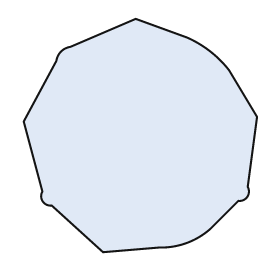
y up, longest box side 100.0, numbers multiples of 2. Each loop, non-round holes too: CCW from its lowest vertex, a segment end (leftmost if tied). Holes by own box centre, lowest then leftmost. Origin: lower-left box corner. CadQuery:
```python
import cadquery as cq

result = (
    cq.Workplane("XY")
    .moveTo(34.0, 0.0)
    .lineTo(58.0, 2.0)
    .threePointArc((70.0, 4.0), (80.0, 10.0))
    .lineTo(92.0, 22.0)
    .threePointArc((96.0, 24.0), (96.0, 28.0))
    .lineTo(100.0, 58.0)
    .lineTo(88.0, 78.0)
    .threePointArc((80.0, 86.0), (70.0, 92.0))
    .lineTo(48.0, 100.0)
    .lineTo(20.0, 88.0)
    .threePointArc((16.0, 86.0), (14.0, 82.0))
    .lineTo(0.0, 56.0)
    .lineTo(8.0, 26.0)
    .threePointArc((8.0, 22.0), (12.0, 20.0))
    .close()
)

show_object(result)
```